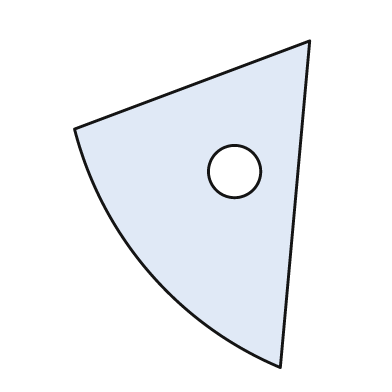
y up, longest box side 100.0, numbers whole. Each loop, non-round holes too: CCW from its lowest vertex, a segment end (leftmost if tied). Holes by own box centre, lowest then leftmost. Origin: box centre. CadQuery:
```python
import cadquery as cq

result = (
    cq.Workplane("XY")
    .moveTo(27.0, -50.0)
    .lineTo(36.0, 50.0)
    .lineTo(-36.0, 23.0)
    .threePointArc((-13.0, -21.0), (27.0, -50.0))
    .close()
    .moveTo(13.0, 10.0)
    .circle(8.0)
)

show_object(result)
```